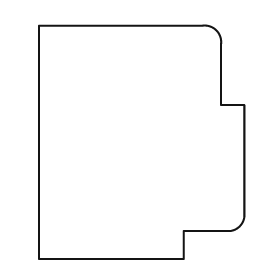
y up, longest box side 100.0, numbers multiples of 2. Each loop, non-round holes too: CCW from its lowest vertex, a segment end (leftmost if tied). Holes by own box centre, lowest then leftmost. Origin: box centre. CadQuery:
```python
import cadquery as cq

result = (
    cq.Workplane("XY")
    .moveTo(-44.0, -50.0)
    .lineTo(18.0, -50.0)
    .lineTo(18.0, -38.0)
    .lineTo(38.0, -38.0)
    .threePointArc((42.0, -36.0), (44.0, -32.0))
    .lineTo(44.0, 16.0)
    .lineTo(34.0, 16.0)
    .lineTo(34.0, 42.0)
    .threePointArc((32.0, 48.0), (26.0, 50.0))
    .lineTo(-44.0, 50.0)
    .close()
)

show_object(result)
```